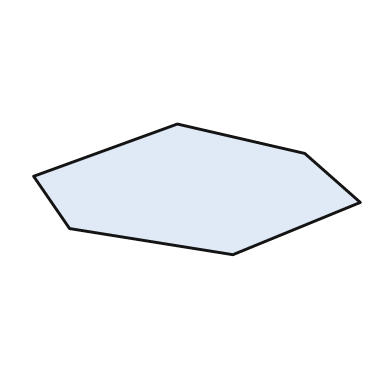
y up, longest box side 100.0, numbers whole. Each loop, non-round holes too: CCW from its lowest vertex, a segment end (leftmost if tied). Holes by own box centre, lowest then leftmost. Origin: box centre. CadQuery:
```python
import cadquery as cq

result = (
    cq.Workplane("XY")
    .moveTo(11.0, -20.0)
    .lineTo(50.0, -4.0)
    .lineTo(33.0, 11.0)
    .lineTo(-6.0, 20.0)
    .lineTo(-50.0, 4.0)
    .lineTo(-39.0, -12.0)
    .close()
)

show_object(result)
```